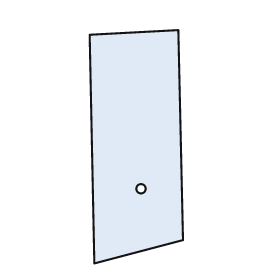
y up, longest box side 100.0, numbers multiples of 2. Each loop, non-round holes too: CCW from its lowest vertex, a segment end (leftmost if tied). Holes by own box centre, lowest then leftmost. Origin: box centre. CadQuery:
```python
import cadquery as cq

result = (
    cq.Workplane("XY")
    .moveTo(-18.0, -50.0)
    .lineTo(20.0, -40.0)
    .lineTo(18.0, 50.0)
    .lineTo(-20.0, 48.0)
    .close()
    .moveTo(2.0, -18.0)
    .circle(2.0)
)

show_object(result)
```